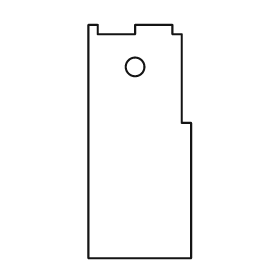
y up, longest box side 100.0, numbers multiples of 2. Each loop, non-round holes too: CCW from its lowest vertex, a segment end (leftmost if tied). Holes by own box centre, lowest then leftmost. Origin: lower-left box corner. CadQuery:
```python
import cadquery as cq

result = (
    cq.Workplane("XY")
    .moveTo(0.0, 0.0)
    .lineTo(44.0, 0.0)
    .lineTo(44.0, 58.0)
    .lineTo(40.0, 58.0)
    .lineTo(40.0, 96.0)
    .lineTo(36.0, 96.0)
    .lineTo(36.0, 100.0)
    .lineTo(20.0, 100.0)
    .lineTo(20.0, 96.0)
    .lineTo(4.0, 96.0)
    .lineTo(4.0, 100.0)
    .lineTo(0.0, 100.0)
    .close()
    .moveTo(20.0, 82.0)
    .circle(4.0)
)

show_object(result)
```